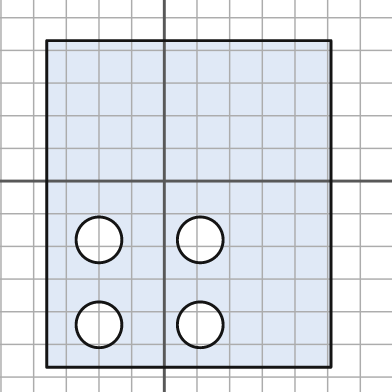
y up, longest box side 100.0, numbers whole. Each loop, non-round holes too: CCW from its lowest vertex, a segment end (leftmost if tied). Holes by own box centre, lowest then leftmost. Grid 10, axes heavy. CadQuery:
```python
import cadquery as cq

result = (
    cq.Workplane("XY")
    .moveTo(-36.0, -57.0)
    .lineTo(51.0, -57.0)
    .lineTo(51.0, 43.0)
    .lineTo(-36.0, 43.0)
    .close()
    .moveTo(-20.0, -44.0)
    .circle(7.0)
    .moveTo(11.0, -44.0)
    .circle(7.0)
    .moveTo(-20.0, -18.0)
    .circle(7.0)
    .moveTo(11.0, -18.0)
    .circle(7.0)
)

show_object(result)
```